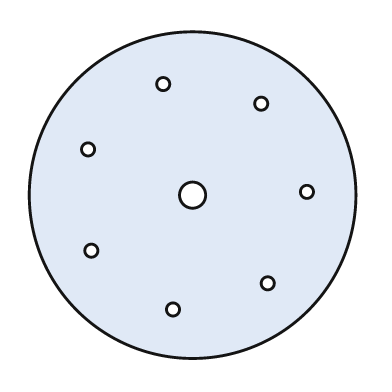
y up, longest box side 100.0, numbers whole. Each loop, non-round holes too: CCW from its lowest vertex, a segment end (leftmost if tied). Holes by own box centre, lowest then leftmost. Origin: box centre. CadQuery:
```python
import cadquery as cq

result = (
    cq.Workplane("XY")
    .moveTo(0.0, 0.0)
    .circle(50.0)
    .moveTo(-6.0, -35.0)
    .circle(2.0)
    .moveTo(23.0, -27.0)
    .circle(2.0)
    .moveTo(-31.0, -17.0)
    .circle(2.0)
    .moveTo(0.0, 0.0)
    .circle(4.0)
    .moveTo(35.0, 1.0)
    .circle(2.0)
    .moveTo(-32.0, 14.0)
    .circle(2.0)
    .moveTo(21.0, 28.0)
    .circle(2.0)
    .moveTo(-9.0, 34.0)
    .circle(2.0)
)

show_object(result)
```